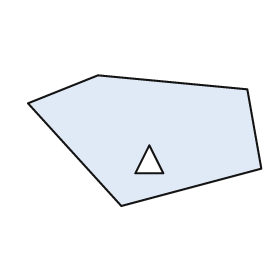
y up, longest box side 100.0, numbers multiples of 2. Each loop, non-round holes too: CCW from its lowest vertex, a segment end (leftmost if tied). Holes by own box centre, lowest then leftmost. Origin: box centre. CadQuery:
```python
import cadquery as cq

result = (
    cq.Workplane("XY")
    .moveTo(-10.0, -28.0)
    .lineTo(50.0, -12.0)
    .lineTo(44.0, 22.0)
    .lineTo(-20.0, 28.0)
    .lineTo(-50.0, 16.0)
    .close()
    .moveTo(-4.0, -14.0)
    .lineTo(8.0, -14.0)
    .lineTo(2.0, -2.0)
    .close()
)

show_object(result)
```